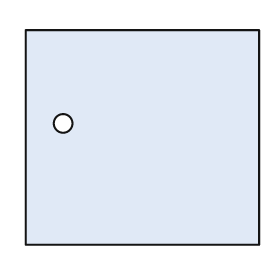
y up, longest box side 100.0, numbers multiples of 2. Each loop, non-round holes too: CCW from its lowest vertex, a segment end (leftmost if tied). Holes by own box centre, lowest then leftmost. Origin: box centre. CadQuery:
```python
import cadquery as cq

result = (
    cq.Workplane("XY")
    .moveTo(-50.0, -46.0)
    .lineTo(50.0, -46.0)
    .lineTo(50.0, 46.0)
    .lineTo(-50.0, 46.0)
    .close()
    .moveTo(-34.0, 6.0)
    .circle(4.0)
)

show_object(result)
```